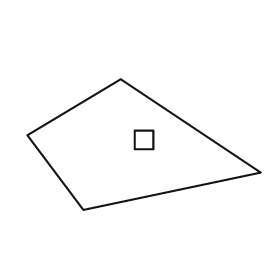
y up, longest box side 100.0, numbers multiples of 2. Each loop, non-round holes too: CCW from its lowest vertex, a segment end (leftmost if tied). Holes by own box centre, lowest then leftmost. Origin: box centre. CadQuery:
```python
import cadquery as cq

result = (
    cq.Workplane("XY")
    .moveTo(-26.0, -28.0)
    .lineTo(50.0, -12.0)
    .lineTo(-10.0, 28.0)
    .lineTo(-50.0, 4.0)
    .close()
    .moveTo(-4.0, -2.0)
    .lineTo(4.0, -2.0)
    .lineTo(4.0, 6.0)
    .lineTo(-4.0, 6.0)
    .close()
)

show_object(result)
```